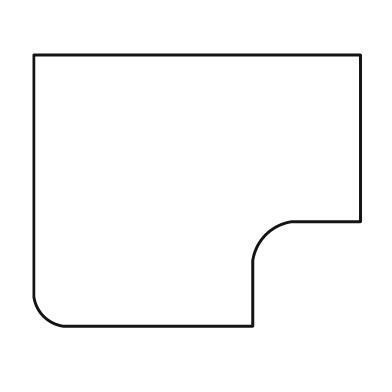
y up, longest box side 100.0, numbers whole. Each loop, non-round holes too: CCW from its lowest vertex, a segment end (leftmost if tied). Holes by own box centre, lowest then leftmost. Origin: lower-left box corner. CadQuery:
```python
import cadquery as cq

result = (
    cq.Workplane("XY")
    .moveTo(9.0, 0.0)
    .lineTo(67.0, 0.0)
    .lineTo(67.0, 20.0)
    .threePointArc((71.0, 28.0), (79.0, 32.0))
    .lineTo(100.0, 32.0)
    .lineTo(100.0, 83.0)
    .lineTo(0.0, 83.0)
    .lineTo(0.0, 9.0)
    .threePointArc((3.0, 3.0), (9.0, 0.0))
    .close()
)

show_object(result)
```